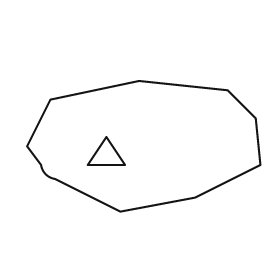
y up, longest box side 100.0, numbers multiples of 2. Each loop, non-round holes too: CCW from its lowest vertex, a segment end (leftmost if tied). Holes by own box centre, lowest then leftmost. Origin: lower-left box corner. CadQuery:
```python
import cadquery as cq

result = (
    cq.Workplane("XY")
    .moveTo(40.0, 0.0)
    .lineTo(72.0, 6.0)
    .lineTo(100.0, 20.0)
    .lineTo(98.0, 40.0)
    .lineTo(86.0, 52.0)
    .lineTo(48.0, 56.0)
    .lineTo(10.0, 48.0)
    .lineTo(0.0, 28.0)
    .lineTo(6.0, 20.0)
    .threePointArc((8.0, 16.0), (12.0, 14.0))
    .close()
    .moveTo(26.0, 20.0)
    .lineTo(42.0, 20.0)
    .lineTo(34.0, 32.0)
    .close()
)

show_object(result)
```